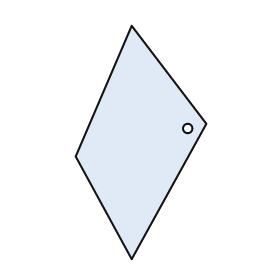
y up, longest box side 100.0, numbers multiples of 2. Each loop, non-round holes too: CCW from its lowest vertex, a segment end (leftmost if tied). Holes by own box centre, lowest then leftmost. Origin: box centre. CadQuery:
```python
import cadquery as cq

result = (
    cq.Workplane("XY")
    .moveTo(-4.0, -50.0)
    .lineTo(28.0, 8.0)
    .lineTo(-4.0, 50.0)
    .lineTo(-28.0, -6.0)
    .close()
    .moveTo(20.0, 6.0)
    .circle(2.0)
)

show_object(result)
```